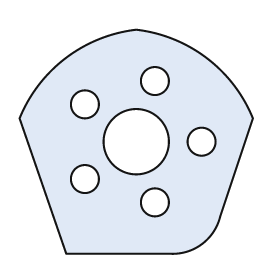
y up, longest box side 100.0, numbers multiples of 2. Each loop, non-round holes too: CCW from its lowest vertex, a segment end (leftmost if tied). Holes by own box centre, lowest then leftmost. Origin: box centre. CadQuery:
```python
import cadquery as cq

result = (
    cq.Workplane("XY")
    .moveTo(-30.0, -48.0)
    .lineTo(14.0, -48.0)
    .threePointArc((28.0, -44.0), (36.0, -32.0))
    .lineTo(50.0, 10.0)
    .threePointArc((30.0, 36.0), (0.0, 48.0))
    .threePointArc((-30.0, 36.0), (-50.0, 10.0))
    .close()
    .moveTo(8.0, -26.0)
    .circle(6.0)
    .moveTo(-22.0, -16.0)
    .circle(6.0)
    .moveTo(0.0, 0.0)
    .circle(14.0)
    .moveTo(28.0, 0.0)
    .circle(6.0)
    .moveTo(-22.0, 16.0)
    .circle(6.0)
    .moveTo(8.0, 26.0)
    .circle(6.0)
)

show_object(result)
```